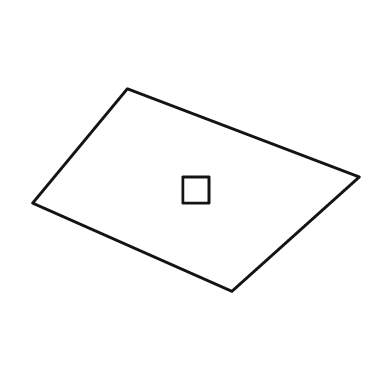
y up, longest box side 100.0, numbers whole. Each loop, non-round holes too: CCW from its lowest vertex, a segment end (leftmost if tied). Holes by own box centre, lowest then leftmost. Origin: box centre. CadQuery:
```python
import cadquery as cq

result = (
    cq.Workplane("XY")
    .moveTo(11.0, -31.0)
    .lineTo(50.0, 4.0)
    .lineTo(-21.0, 31.0)
    .lineTo(-50.0, -4.0)
    .close()
    .moveTo(-4.0, -4.0)
    .lineTo(4.0, -4.0)
    .lineTo(4.0, 4.0)
    .lineTo(-4.0, 4.0)
    .close()
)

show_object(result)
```